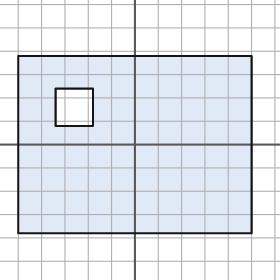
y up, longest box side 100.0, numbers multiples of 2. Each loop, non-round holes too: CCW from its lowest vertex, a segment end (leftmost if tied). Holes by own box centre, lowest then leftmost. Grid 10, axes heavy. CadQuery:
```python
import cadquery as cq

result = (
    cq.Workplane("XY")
    .moveTo(-50.0, -38.0)
    .lineTo(50.0, -38.0)
    .lineTo(50.0, 38.0)
    .lineTo(-50.0, 38.0)
    .close()
    .moveTo(-34.0, 8.0)
    .lineTo(-18.0, 8.0)
    .lineTo(-18.0, 24.0)
    .lineTo(-34.0, 24.0)
    .close()
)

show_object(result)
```